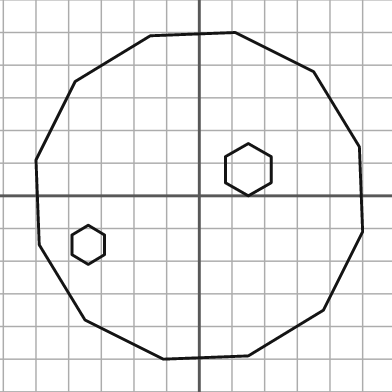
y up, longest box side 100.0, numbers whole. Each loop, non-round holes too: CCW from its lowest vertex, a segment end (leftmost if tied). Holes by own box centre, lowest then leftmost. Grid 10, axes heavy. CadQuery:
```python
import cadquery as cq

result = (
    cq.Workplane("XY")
    .moveTo(-11.0, -50.0)
    .lineTo(15.0, -49.0)
    .lineTo(38.0, -35.0)
    .lineTo(50.0, -11.0)
    .lineTo(49.0, 15.0)
    .lineTo(35.0, 38.0)
    .lineTo(11.0, 50.0)
    .lineTo(-15.0, 49.0)
    .lineTo(-38.0, 35.0)
    .lineTo(-50.0, 11.0)
    .lineTo(-49.0, -15.0)
    .lineTo(-35.0, -38.0)
    .close()
    .moveTo(-34.0, -21.0)
    .lineTo(-29.0, -18.0)
    .lineTo(-29.0, -12.0)
    .lineTo(-34.0, -9.0)
    .lineTo(-39.0, -12.0)
    .lineTo(-39.0, -18.0)
    .close()
    .moveTo(15.0, 0.0)
    .lineTo(22.0, 4.0)
    .lineTo(22.0, 12.0)
    .lineTo(15.0, 16.0)
    .lineTo(8.0, 12.0)
    .lineTo(8.0, 4.0)
    .close()
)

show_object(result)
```